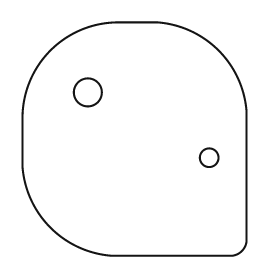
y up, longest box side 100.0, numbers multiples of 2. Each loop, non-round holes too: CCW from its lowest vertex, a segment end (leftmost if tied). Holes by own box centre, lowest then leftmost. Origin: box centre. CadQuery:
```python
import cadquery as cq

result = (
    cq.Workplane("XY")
    .moveTo(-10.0, -50.0)
    .lineTo(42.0, -50.0)
    .threePointArc((46.0, -48.0), (48.0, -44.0))
    .lineTo(48.0, 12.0)
    .threePointArc((36.0, 38.0), (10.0, 50.0))
    .lineTo(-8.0, 50.0)
    .threePointArc((-36.0, 38.0), (-48.0, 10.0))
    .lineTo(-48.0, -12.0)
    .threePointArc((-36.0, -38.0), (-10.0, -50.0))
    .close()
    .moveTo(32.0, -8.0)
    .circle(4.0)
    .moveTo(-20.0, 20.0)
    .circle(6.0)
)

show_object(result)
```